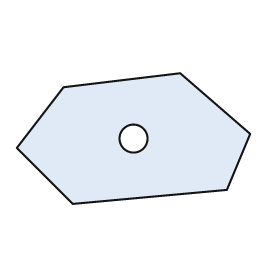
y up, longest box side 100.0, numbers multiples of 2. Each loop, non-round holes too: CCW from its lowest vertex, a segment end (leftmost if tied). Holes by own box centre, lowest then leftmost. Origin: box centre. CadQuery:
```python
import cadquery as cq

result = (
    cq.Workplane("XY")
    .moveTo(-26.0, -28.0)
    .lineTo(40.0, -22.0)
    .lineTo(50.0, 2.0)
    .lineTo(20.0, 28.0)
    .lineTo(-30.0, 22.0)
    .lineTo(-50.0, -4.0)
    .close()
    .moveTo(0.0, 0.0)
    .circle(6.0)
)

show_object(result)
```